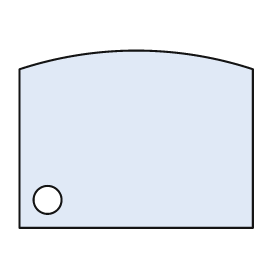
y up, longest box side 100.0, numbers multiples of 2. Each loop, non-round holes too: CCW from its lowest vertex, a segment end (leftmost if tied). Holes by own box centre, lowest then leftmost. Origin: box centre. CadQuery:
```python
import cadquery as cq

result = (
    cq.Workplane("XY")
    .moveTo(-50.0, -38.0)
    .lineTo(50.0, -38.0)
    .lineTo(50.0, 30.0)
    .threePointArc((0.0, 38.0), (-50.0, 30.0))
    .close()
    .moveTo(-38.0, -26.0)
    .circle(6.0)
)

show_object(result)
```